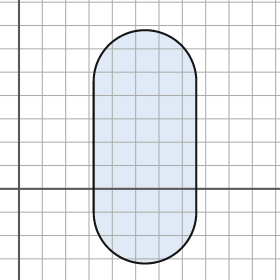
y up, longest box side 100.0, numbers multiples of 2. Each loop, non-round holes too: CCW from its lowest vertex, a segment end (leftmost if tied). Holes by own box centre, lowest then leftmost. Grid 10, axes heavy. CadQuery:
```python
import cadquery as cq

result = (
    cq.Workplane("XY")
    .moveTo(32.0, -10.0)
    .threePointArc((54.0, -32.0), (76.0, -10.0))
    .lineTo(76.0, 46.0)
    .threePointArc((54.0, 68.0), (32.0, 46.0))
    .close()
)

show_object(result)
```